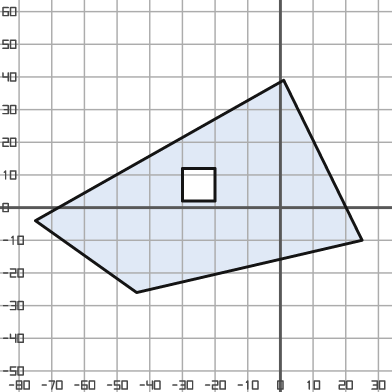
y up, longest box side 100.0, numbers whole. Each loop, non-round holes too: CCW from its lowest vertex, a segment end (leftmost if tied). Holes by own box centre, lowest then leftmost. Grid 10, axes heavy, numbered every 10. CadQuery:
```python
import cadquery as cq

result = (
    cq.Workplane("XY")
    .moveTo(-44.0, -26.0)
    .lineTo(25.0, -10.0)
    .lineTo(1.0, 39.0)
    .lineTo(-75.0, -4.0)
    .close()
    .moveTo(-30.0, 2.0)
    .lineTo(-20.0, 2.0)
    .lineTo(-20.0, 12.0)
    .lineTo(-30.0, 12.0)
    .close()
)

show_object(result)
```